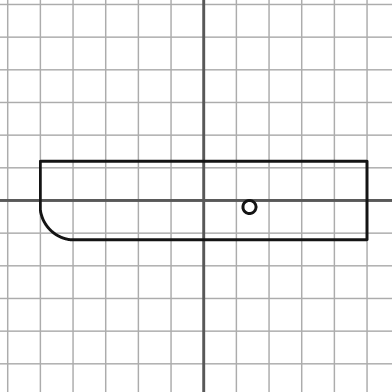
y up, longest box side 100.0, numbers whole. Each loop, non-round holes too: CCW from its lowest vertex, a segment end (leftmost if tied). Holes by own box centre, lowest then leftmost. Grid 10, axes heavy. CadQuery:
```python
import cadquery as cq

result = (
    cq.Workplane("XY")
    .moveTo(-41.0, -12.0)
    .lineTo(50.0, -12.0)
    .lineTo(50.0, 12.0)
    .lineTo(-50.0, 12.0)
    .lineTo(-50.0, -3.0)
    .threePointArc((-47.0, -9.0), (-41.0, -12.0))
    .close()
    .moveTo(14.0, -2.0)
    .circle(2.0)
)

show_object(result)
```